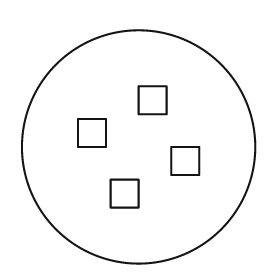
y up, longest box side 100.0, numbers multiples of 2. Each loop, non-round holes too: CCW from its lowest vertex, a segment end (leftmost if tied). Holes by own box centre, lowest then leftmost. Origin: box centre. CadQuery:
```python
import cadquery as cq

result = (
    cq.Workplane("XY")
    .moveTo(0.0, 0.0)
    .circle(50.0)
    .moveTo(-12.0, -26.0)
    .lineTo(0.0, -26.0)
    .lineTo(0.0, -14.0)
    .lineTo(-12.0, -14.0)
    .close()
    .moveTo(14.0, -12.0)
    .lineTo(26.0, -12.0)
    .lineTo(26.0, 0.0)
    .lineTo(14.0, 0.0)
    .close()
    .moveTo(-26.0, 0.0)
    .lineTo(-14.0, 0.0)
    .lineTo(-14.0, 12.0)
    .lineTo(-26.0, 12.0)
    .close()
    .moveTo(0.0, 14.0)
    .lineTo(12.0, 14.0)
    .lineTo(12.0, 26.0)
    .lineTo(0.0, 26.0)
    .close()
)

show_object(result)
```